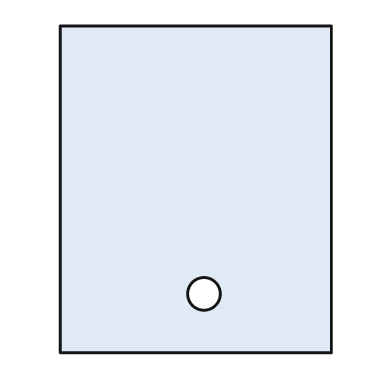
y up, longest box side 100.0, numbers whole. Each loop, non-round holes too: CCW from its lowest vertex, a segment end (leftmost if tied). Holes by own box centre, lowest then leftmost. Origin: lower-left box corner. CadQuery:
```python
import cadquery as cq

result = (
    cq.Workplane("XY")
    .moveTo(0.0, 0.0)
    .lineTo(83.0, 0.0)
    .lineTo(83.0, 100.0)
    .lineTo(0.0, 100.0)
    .close()
    .moveTo(44.0, 18.0)
    .circle(5.0)
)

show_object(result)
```